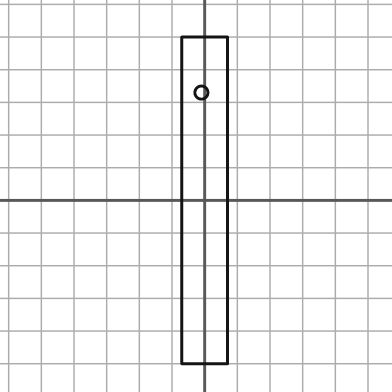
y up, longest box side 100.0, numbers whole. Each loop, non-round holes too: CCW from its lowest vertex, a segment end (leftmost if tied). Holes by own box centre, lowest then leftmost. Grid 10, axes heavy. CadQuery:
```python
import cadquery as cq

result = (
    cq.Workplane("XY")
    .moveTo(-7.0, -50.0)
    .lineTo(7.0, -50.0)
    .lineTo(7.0, 50.0)
    .lineTo(-7.0, 50.0)
    .close()
    .moveTo(-1.0, 33.0)
    .circle(2.0)
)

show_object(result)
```